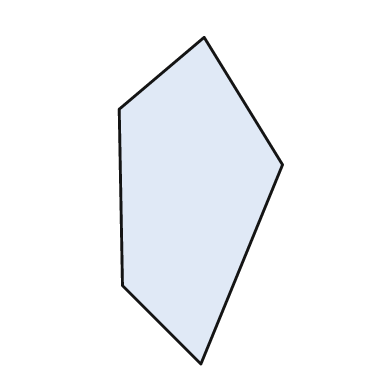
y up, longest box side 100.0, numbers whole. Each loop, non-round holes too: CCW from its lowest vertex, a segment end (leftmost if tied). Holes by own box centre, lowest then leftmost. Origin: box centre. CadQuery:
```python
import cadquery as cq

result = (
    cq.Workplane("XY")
    .moveTo(0.0, -50.0)
    .lineTo(25.0, 11.0)
    .lineTo(1.0, 50.0)
    .lineTo(-25.0, 28.0)
    .lineTo(-24.0, -26.0)
    .close()
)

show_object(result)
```